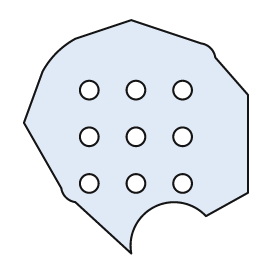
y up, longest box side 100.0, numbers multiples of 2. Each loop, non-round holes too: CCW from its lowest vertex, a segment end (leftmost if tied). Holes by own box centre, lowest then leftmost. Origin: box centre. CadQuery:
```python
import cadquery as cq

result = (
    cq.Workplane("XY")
    .moveTo(-2.0, -50.0)
    .threePointArc((8.0, -30.0), (30.0, -34.0))
    .lineTo(48.0, -24.0)
    .lineTo(48.0, 18.0)
    .lineTo(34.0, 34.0)
    .threePointArc((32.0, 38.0), (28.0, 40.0))
    .lineTo(-2.0, 50.0)
    .lineTo(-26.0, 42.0)
    .threePointArc((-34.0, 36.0), (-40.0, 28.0))
    .lineTo(-48.0, 6.0)
    .lineTo(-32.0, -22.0)
    .threePointArc((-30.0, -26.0), (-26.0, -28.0))
    .close()
    .moveTo(-20.0, -20.0)
    .circle(4.0)
    .moveTo(0.0, -20.0)
    .circle(4.0)
    .moveTo(20.0, -20.0)
    .circle(4.0)
    .moveTo(-20.0, 0.0)
    .circle(4.0)
    .moveTo(0.0, 0.0)
    .circle(4.0)
    .moveTo(20.0, 0.0)
    .circle(4.0)
    .moveTo(-20.0, 20.0)
    .circle(4.0)
    .moveTo(0.0, 20.0)
    .circle(4.0)
    .moveTo(20.0, 20.0)
    .circle(4.0)
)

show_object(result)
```